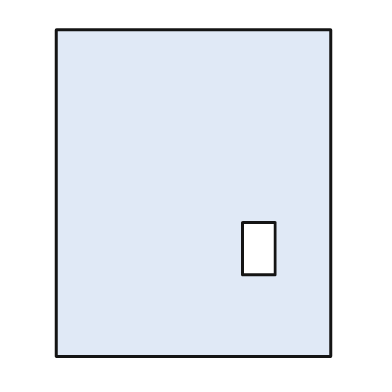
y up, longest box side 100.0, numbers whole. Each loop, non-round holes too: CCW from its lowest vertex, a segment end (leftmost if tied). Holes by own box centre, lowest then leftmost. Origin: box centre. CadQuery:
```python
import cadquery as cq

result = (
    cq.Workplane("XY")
    .moveTo(-42.0, -50.0)
    .lineTo(42.0, -50.0)
    .lineTo(42.0, 50.0)
    .lineTo(-42.0, 50.0)
    .close()
    .moveTo(15.0, -25.0)
    .lineTo(25.0, -25.0)
    .lineTo(25.0, -9.0)
    .lineTo(15.0, -9.0)
    .close()
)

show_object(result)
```